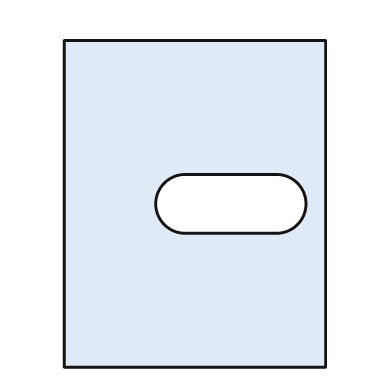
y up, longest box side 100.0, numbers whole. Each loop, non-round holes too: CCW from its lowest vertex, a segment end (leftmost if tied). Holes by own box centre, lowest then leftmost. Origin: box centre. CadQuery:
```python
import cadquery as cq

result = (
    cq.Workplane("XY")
    .moveTo(-40.0, -50.0)
    .lineTo(40.0, -50.0)
    .lineTo(40.0, 50.0)
    .lineTo(-40.0, 50.0)
    .close()
    .moveTo(-3.0, -9.0)
    .lineTo(25.0, -9.0)
    .threePointArc((34.0, 0.0), (25.0, 9.0))
    .lineTo(-3.0, 9.0)
    .threePointArc((-12.0, 0.0), (-3.0, -9.0))
    .close()
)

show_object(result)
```